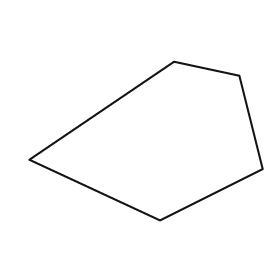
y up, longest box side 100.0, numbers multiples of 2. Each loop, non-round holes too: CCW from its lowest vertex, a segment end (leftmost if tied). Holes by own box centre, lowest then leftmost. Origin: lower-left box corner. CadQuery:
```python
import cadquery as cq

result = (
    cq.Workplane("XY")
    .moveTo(56.0, 0.0)
    .lineTo(100.0, 22.0)
    .lineTo(90.0, 62.0)
    .lineTo(62.0, 68.0)
    .lineTo(0.0, 26.0)
    .close()
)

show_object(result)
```